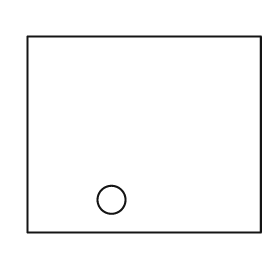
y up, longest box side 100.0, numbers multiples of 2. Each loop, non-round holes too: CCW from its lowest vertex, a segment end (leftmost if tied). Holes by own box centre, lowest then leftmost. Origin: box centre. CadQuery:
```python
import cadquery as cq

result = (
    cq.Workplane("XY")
    .moveTo(-50.0, -42.0)
    .lineTo(50.0, -42.0)
    .lineTo(50.0, 42.0)
    .lineTo(-50.0, 42.0)
    .close()
    .moveTo(-14.0, -28.0)
    .circle(6.0)
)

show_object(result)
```